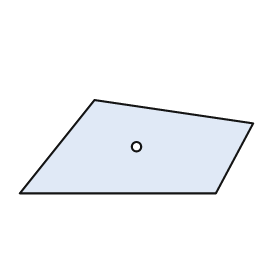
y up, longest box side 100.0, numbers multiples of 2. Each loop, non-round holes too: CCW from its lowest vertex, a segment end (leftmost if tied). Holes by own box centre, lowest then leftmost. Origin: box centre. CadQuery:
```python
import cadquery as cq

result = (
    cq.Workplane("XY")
    .moveTo(-50.0, -20.0)
    .lineTo(34.0, -20.0)
    .lineTo(50.0, 10.0)
    .lineTo(-18.0, 20.0)
    .close()
    .moveTo(0.0, 0.0)
    .circle(2.0)
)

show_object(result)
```